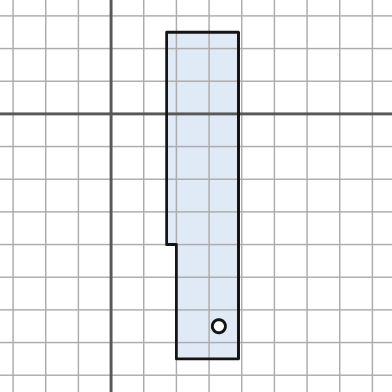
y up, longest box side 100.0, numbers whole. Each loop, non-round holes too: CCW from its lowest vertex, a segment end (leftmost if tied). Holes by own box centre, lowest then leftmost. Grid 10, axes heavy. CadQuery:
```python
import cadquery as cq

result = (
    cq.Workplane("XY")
    .moveTo(20.0, -75.0)
    .lineTo(39.0, -75.0)
    .lineTo(39.0, 25.0)
    .lineTo(17.0, 25.0)
    .lineTo(17.0, -40.0)
    .lineTo(20.0, -40.0)
    .close()
    .moveTo(33.0, -65.0)
    .circle(2.0)
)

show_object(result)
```